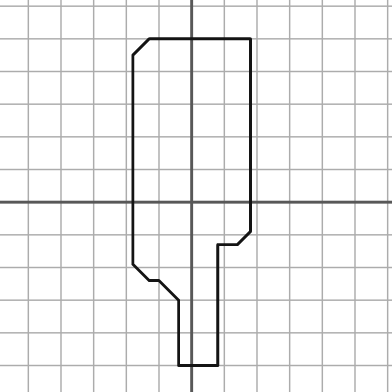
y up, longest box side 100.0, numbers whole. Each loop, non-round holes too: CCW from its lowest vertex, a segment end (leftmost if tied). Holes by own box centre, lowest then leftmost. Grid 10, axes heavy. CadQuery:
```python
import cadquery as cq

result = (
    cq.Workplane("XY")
    .moveTo(-4.0, -50.0)
    .lineTo(8.0, -50.0)
    .lineTo(8.0, -13.0)
    .lineTo(14.0, -13.0)
    .lineTo(18.0, -9.0)
    .lineTo(18.0, 50.0)
    .lineTo(-13.0, 50.0)
    .lineTo(-18.0, 45.0)
    .lineTo(-18.0, -19.0)
    .lineTo(-13.0, -24.0)
    .lineTo(-10.0, -24.0)
    .lineTo(-4.0, -30.0)
    .close()
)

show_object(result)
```